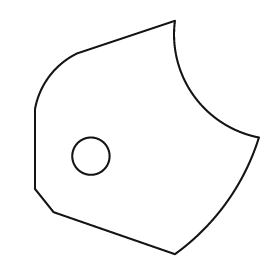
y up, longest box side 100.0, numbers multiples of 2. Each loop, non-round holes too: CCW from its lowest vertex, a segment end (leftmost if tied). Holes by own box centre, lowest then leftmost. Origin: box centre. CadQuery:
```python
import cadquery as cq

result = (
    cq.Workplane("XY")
    .moveTo(12.0, -50.0)
    .threePointArc((34.0, -28.0), (48.0, 0.0))
    .threePointArc((20.0, 18.0), (12.0, 50.0))
    .lineTo(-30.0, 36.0)
    .threePointArc((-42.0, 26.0), (-48.0, 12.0))
    .lineTo(-48.0, -22.0)
    .lineTo(-40.0, -32.0)
    .close()
    .moveTo(-24.0, -8.0)
    .circle(8.0)
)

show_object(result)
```